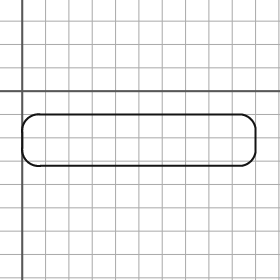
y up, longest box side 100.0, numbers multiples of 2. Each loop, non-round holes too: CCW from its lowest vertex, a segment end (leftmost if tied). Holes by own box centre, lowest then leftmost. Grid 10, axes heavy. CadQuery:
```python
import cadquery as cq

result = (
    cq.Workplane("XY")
    .moveTo(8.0, -32.0)
    .lineTo(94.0, -32.0)
    .threePointArc((98.0, -30.0), (100.0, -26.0))
    .lineTo(100.0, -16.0)
    .threePointArc((98.0, -12.0), (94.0, -10.0))
    .lineTo(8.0, -10.0)
    .threePointArc((2.0, -12.0), (0.0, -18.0))
    .lineTo(0.0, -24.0)
    .threePointArc((2.0, -30.0), (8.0, -32.0))
    .close()
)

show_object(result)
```